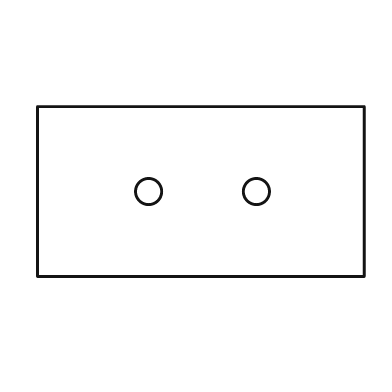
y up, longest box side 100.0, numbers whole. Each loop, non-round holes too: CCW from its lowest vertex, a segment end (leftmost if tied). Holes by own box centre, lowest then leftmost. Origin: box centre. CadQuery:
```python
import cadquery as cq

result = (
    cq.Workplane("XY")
    .moveTo(-50.0, -26.0)
    .lineTo(50.0, -26.0)
    .lineTo(50.0, 26.0)
    .lineTo(-50.0, 26.0)
    .close()
    .moveTo(-16.0, 0.0)
    .circle(4.0)
    .moveTo(17.0, 0.0)
    .circle(4.0)
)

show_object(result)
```